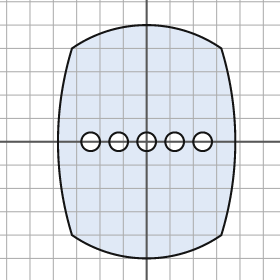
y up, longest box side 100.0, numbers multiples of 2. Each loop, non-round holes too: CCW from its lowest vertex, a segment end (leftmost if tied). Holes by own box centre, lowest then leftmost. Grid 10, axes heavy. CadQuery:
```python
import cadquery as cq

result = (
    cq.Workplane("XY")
    .moveTo(-32.0, -40.0)
    .threePointArc((0.0, -50.0), (32.0, -40.0))
    .threePointArc((38.0, 0.0), (32.0, 40.0))
    .threePointArc((0.0, 50.0), (-32.0, 40.0))
    .threePointArc((-38.0, 0.0), (-32.0, -40.0))
    .close()
    .moveTo(-24.0, 0.0)
    .circle(4.0)
    .moveTo(-12.0, 0.0)
    .circle(4.0)
    .moveTo(0.0, 0.0)
    .circle(4.0)
    .moveTo(12.0, 0.0)
    .circle(4.0)
    .moveTo(24.0, 0.0)
    .circle(4.0)
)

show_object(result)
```